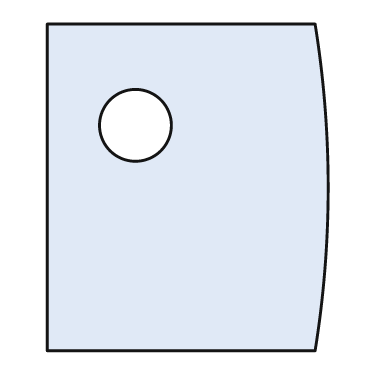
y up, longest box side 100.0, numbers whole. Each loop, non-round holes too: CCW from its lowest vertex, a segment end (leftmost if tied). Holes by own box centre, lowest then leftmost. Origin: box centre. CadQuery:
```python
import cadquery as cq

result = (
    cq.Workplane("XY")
    .moveTo(-43.0, -50.0)
    .lineTo(39.0, -50.0)
    .threePointArc((43.0, 0.0), (39.0, 50.0))
    .lineTo(-43.0, 50.0)
    .close()
    .moveTo(-16.0, 19.0)
    .circle(11.0)
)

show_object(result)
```